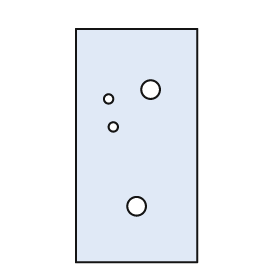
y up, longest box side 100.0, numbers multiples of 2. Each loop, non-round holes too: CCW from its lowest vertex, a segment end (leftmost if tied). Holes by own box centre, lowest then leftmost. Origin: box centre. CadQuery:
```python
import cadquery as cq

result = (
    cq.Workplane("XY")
    .moveTo(-26.0, -50.0)
    .lineTo(26.0, -50.0)
    .lineTo(26.0, 50.0)
    .lineTo(-26.0, 50.0)
    .close()
    .moveTo(0.0, -26.0)
    .circle(4.0)
    .moveTo(-10.0, 8.0)
    .circle(2.0)
    .moveTo(-12.0, 20.0)
    .circle(2.0)
    .moveTo(6.0, 24.0)
    .circle(4.0)
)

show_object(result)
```